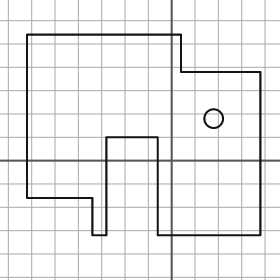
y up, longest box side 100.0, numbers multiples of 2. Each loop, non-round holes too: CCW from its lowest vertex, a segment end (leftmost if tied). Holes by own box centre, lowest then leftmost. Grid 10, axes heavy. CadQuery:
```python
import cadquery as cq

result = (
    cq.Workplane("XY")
    .moveTo(-34.0, -32.0)
    .lineTo(-28.0, -32.0)
    .lineTo(-28.0, 10.0)
    .lineTo(-6.0, 10.0)
    .lineTo(-6.0, -32.0)
    .lineTo(38.0, -32.0)
    .lineTo(38.0, 38.0)
    .lineTo(4.0, 38.0)
    .lineTo(4.0, 54.0)
    .lineTo(-62.0, 54.0)
    .lineTo(-62.0, -16.0)
    .lineTo(-34.0, -16.0)
    .close()
    .moveTo(18.0, 18.0)
    .circle(4.0)
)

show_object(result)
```